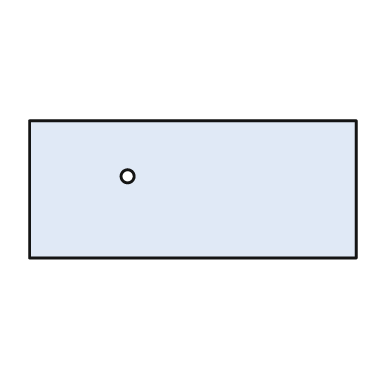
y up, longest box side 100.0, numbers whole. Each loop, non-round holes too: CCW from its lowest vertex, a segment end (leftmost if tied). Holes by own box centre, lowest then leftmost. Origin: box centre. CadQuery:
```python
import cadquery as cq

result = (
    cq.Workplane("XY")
    .moveTo(-50.0, -21.0)
    .lineTo(50.0, -21.0)
    .lineTo(50.0, 21.0)
    .lineTo(-50.0, 21.0)
    .close()
    .moveTo(-20.0, 4.0)
    .circle(2.0)
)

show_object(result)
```